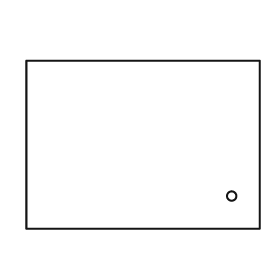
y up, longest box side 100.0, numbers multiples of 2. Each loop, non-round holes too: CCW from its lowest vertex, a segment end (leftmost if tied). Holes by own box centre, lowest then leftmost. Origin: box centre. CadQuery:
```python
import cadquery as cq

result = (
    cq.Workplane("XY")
    .moveTo(-50.0, -36.0)
    .lineTo(50.0, -36.0)
    .lineTo(50.0, 36.0)
    .lineTo(-50.0, 36.0)
    .close()
    .moveTo(38.0, -22.0)
    .circle(2.0)
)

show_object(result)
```